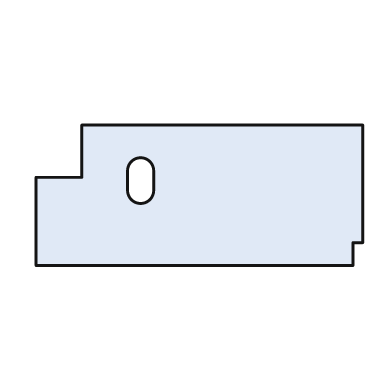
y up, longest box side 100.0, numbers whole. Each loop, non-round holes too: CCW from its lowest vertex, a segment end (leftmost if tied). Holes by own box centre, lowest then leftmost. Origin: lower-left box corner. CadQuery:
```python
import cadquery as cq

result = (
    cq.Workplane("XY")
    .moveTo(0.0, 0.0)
    .lineTo(97.0, 0.0)
    .lineTo(97.0, 7.0)
    .lineTo(100.0, 7.0)
    .lineTo(100.0, 43.0)
    .lineTo(14.0, 43.0)
    .lineTo(14.0, 27.0)
    .lineTo(0.0, 27.0)
    .close()
    .moveTo(28.0, 23.0)
    .threePointArc((32.0, 19.0), (36.0, 23.0))
    .lineTo(36.0, 29.0)
    .threePointArc((32.0, 33.0), (28.0, 29.0))
    .close()
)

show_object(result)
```